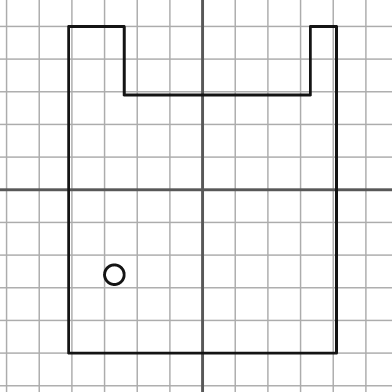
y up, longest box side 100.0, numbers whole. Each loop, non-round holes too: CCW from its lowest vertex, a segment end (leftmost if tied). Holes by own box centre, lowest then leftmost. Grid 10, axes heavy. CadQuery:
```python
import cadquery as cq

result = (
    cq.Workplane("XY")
    .moveTo(-41.0, -50.0)
    .lineTo(41.0, -50.0)
    .lineTo(41.0, 50.0)
    .lineTo(33.0, 50.0)
    .lineTo(33.0, 29.0)
    .lineTo(-24.0, 29.0)
    .lineTo(-24.0, 50.0)
    .lineTo(-41.0, 50.0)
    .close()
    .moveTo(-27.0, -26.0)
    .circle(3.0)
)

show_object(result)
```